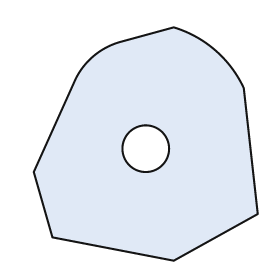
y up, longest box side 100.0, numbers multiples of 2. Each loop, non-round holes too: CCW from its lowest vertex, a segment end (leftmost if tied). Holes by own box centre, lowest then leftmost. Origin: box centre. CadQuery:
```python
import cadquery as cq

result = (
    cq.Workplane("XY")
    .moveTo(12.0, -50.0)
    .lineTo(48.0, -30.0)
    .lineTo(42.0, 24.0)
    .threePointArc((30.0, 40.0), (12.0, 50.0))
    .lineTo(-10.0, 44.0)
    .threePointArc((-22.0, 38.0), (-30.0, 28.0))
    .lineTo(-48.0, -12.0)
    .lineTo(-40.0, -40.0)
    .close()
    .moveTo(0.0, -2.0)
    .circle(10.0)
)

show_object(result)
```